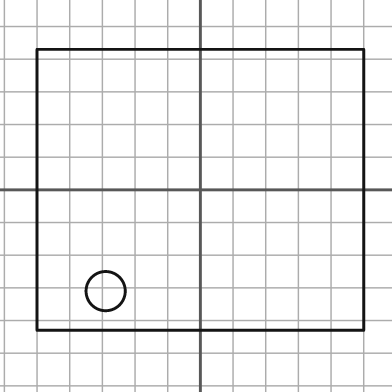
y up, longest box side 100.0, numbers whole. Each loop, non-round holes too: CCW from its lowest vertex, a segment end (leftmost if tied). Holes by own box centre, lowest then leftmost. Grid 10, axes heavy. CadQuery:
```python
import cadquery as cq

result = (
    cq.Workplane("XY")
    .moveTo(-50.0, -43.0)
    .lineTo(50.0, -43.0)
    .lineTo(50.0, 43.0)
    .lineTo(-50.0, 43.0)
    .close()
    .moveTo(-29.0, -31.0)
    .circle(6.0)
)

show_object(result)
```